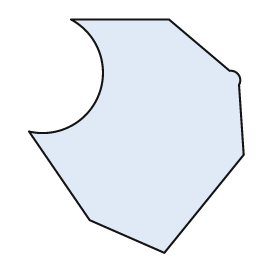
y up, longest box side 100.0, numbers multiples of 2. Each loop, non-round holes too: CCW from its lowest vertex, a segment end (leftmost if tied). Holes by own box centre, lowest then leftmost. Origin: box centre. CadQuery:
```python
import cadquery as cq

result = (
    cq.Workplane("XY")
    .moveTo(12.0, -50.0)
    .lineTo(46.0, -8.0)
    .lineTo(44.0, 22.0)
    .threePointArc((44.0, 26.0), (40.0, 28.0))
    .lineTo(14.0, 50.0)
    .lineTo(-28.0, 50.0)
    .threePointArc((-16.0, 18.0), (-46.0, 2.0))
    .lineTo(-20.0, -36.0)
    .close()
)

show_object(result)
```